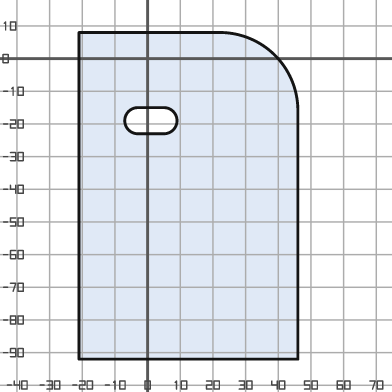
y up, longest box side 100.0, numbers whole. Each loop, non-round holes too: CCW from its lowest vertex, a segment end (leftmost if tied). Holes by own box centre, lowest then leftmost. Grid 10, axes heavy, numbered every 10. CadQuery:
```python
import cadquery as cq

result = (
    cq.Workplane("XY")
    .moveTo(-21.0, -92.0)
    .lineTo(46.0, -92.0)
    .lineTo(46.0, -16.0)
    .threePointArc((39.0, 1.0), (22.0, 8.0))
    .lineTo(-21.0, 8.0)
    .close()
    .moveTo(-3.0, -23.0)
    .lineTo(5.0, -23.0)
    .threePointArc((9.0, -19.0), (5.0, -15.0))
    .lineTo(-3.0, -15.0)
    .threePointArc((-7.0, -19.0), (-3.0, -23.0))
    .close()
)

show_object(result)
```